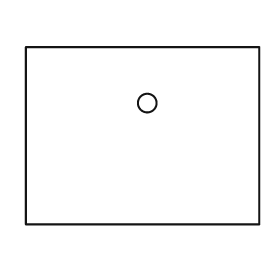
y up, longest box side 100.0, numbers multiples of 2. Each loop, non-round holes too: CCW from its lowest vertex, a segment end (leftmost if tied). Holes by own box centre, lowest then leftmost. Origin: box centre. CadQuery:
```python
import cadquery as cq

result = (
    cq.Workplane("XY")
    .moveTo(-50.0, -38.0)
    .lineTo(50.0, -38.0)
    .lineTo(50.0, 38.0)
    .lineTo(-50.0, 38.0)
    .close()
    .moveTo(2.0, 14.0)
    .circle(4.0)
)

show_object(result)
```